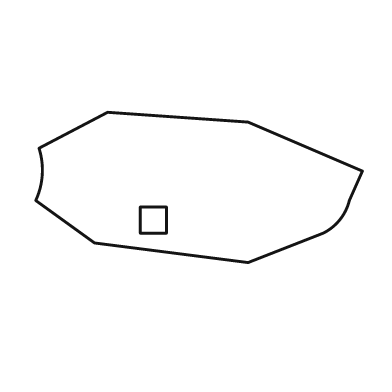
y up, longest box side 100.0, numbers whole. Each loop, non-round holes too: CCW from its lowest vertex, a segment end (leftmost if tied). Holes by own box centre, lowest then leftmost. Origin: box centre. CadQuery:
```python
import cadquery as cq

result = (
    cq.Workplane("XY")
    .moveTo(15.0, -23.0)
    .lineTo(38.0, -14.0)
    .threePointArc((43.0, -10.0), (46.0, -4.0))
    .lineTo(50.0, 5.0)
    .lineTo(15.0, 20.0)
    .lineTo(-28.0, 23.0)
    .lineTo(-49.0, 12.0)
    .threePointArc((-48.0, 4.0), (-50.0, -4.0))
    .lineTo(-32.0, -17.0)
    .close()
    .moveTo(-18.0, -14.0)
    .lineTo(-10.0, -14.0)
    .lineTo(-10.0, -6.0)
    .lineTo(-18.0, -6.0)
    .close()
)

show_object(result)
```